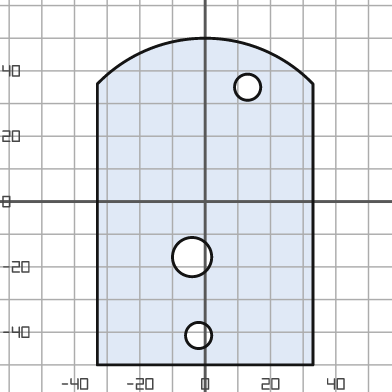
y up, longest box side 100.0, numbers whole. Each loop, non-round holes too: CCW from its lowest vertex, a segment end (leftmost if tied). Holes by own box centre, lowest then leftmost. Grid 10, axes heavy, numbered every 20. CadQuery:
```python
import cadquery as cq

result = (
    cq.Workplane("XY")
    .moveTo(-33.0, -50.0)
    .lineTo(33.0, -50.0)
    .lineTo(33.0, 36.0)
    .threePointArc((0.0, 50.0), (-33.0, 36.0))
    .close()
    .moveTo(-2.0, -41.0)
    .circle(4.0)
    .moveTo(-4.0, -17.0)
    .circle(6.0)
    .moveTo(13.0, 35.0)
    .circle(4.0)
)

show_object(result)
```